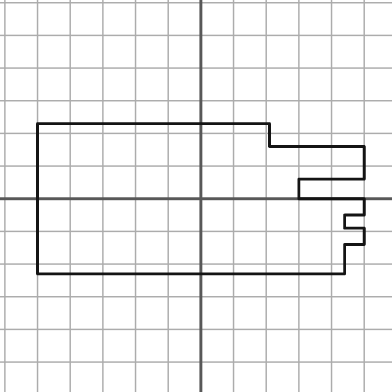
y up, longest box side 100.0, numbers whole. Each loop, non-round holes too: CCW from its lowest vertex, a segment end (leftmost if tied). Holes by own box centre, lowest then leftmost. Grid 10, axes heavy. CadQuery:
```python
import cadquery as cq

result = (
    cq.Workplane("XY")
    .moveTo(-50.0, -23.0)
    .lineTo(44.0, -23.0)
    .lineTo(44.0, -14.0)
    .lineTo(50.0, -14.0)
    .lineTo(50.0, -9.0)
    .lineTo(44.0, -9.0)
    .lineTo(44.0, -5.0)
    .lineTo(50.0, -5.0)
    .lineTo(50.0, 0.0)
    .lineTo(30.0, 0.0)
    .lineTo(30.0, 6.0)
    .lineTo(50.0, 6.0)
    .lineTo(50.0, 16.0)
    .lineTo(21.0, 16.0)
    .lineTo(21.0, 23.0)
    .lineTo(-50.0, 23.0)
    .close()
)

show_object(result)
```